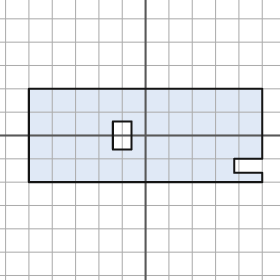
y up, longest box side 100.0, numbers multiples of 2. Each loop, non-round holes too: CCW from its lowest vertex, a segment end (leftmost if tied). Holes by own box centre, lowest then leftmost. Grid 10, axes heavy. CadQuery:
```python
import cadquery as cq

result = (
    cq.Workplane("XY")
    .moveTo(-50.0, -20.0)
    .lineTo(50.0, -20.0)
    .lineTo(50.0, -16.0)
    .lineTo(38.0, -16.0)
    .lineTo(38.0, -10.0)
    .lineTo(50.0, -10.0)
    .lineTo(50.0, 20.0)
    .lineTo(-50.0, 20.0)
    .close()
    .moveTo(-14.0, -6.0)
    .lineTo(-6.0, -6.0)
    .lineTo(-6.0, 6.0)
    .lineTo(-14.0, 6.0)
    .close()
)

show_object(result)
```